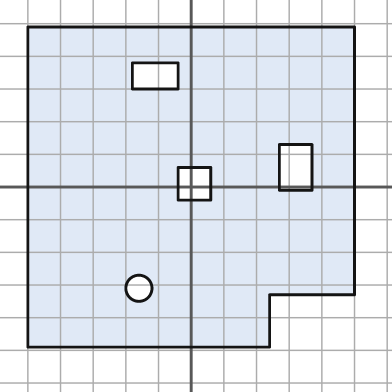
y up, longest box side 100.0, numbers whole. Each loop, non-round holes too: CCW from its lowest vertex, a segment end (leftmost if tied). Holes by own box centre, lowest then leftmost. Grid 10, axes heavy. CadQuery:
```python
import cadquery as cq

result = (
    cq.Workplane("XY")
    .moveTo(-50.0, -49.0)
    .lineTo(24.0, -49.0)
    .lineTo(24.0, -33.0)
    .lineTo(50.0, -33.0)
    .lineTo(50.0, 49.0)
    .lineTo(-50.0, 49.0)
    .close()
    .moveTo(-16.0, -31.0)
    .circle(4.0)
    .moveTo(-4.0, -4.0)
    .lineTo(6.0, -4.0)
    .lineTo(6.0, 6.0)
    .lineTo(-4.0, 6.0)
    .close()
    .moveTo(27.0, -1.0)
    .lineTo(37.0, -1.0)
    .lineTo(37.0, 13.0)
    .lineTo(27.0, 13.0)
    .close()
    .moveTo(-18.0, 30.0)
    .lineTo(-4.0, 30.0)
    .lineTo(-4.0, 38.0)
    .lineTo(-18.0, 38.0)
    .close()
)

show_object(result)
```